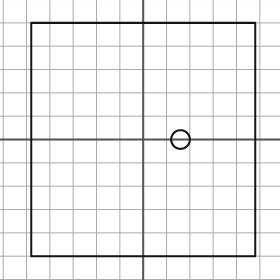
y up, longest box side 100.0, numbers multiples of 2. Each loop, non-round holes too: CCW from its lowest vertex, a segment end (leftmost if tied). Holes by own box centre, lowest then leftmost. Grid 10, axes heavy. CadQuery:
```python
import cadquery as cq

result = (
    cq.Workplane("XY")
    .moveTo(-48.0, -50.0)
    .lineTo(48.0, -50.0)
    .lineTo(48.0, 50.0)
    .lineTo(-48.0, 50.0)
    .close()
    .moveTo(16.0, 0.0)
    .circle(4.0)
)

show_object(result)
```